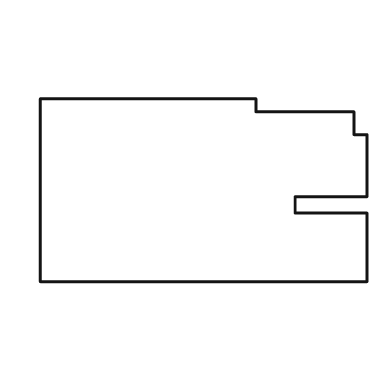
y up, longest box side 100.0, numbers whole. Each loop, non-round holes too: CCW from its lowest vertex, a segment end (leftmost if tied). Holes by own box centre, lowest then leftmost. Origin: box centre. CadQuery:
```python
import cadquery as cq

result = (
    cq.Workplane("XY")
    .moveTo(-50.0, -28.0)
    .lineTo(50.0, -28.0)
    .lineTo(50.0, -7.0)
    .lineTo(28.0, -7.0)
    .lineTo(28.0, -2.0)
    .lineTo(50.0, -2.0)
    .lineTo(50.0, 17.0)
    .lineTo(46.0, 17.0)
    .lineTo(46.0, 24.0)
    .lineTo(16.0, 24.0)
    .lineTo(16.0, 28.0)
    .lineTo(-50.0, 28.0)
    .close()
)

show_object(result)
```